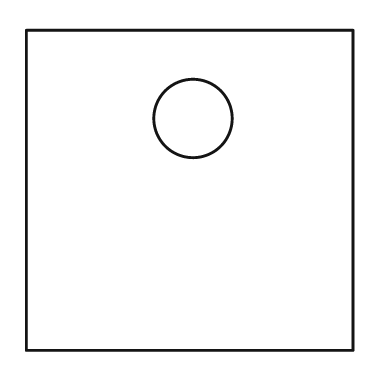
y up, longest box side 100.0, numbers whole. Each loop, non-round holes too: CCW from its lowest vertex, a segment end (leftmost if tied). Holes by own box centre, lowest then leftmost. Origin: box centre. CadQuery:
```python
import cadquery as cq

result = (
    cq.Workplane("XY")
    .moveTo(-50.0, -49.0)
    .lineTo(50.0, -49.0)
    .lineTo(50.0, 49.0)
    .lineTo(-50.0, 49.0)
    .close()
    .moveTo(1.0, 22.0)
    .circle(12.0)
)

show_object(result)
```